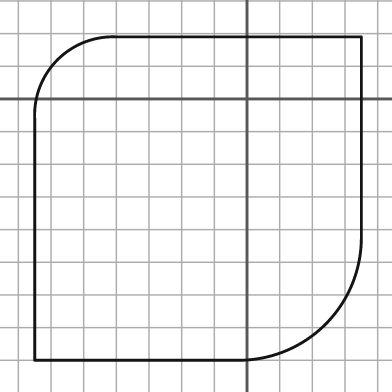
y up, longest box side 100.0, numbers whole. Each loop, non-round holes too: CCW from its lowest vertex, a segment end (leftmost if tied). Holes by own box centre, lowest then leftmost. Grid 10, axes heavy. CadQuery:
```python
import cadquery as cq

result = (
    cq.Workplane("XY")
    .moveTo(-65.0, -80.0)
    .lineTo(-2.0, -80.0)
    .threePointArc((24.0, -69.0), (35.0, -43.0))
    .lineTo(35.0, 19.0)
    .lineTo(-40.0, 19.0)
    .threePointArc((-58.0, 12.0), (-65.0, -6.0))
    .close()
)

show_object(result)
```